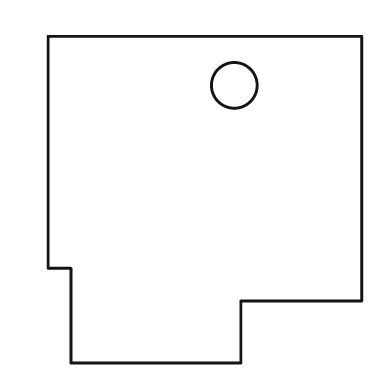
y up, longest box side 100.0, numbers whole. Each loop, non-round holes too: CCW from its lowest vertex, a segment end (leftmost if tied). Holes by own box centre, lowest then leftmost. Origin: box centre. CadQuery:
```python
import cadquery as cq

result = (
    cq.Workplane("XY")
    .moveTo(-41.0, -50.0)
    .lineTo(11.0, -50.0)
    .lineTo(11.0, -31.0)
    .lineTo(48.0, -31.0)
    .lineTo(48.0, 50.0)
    .lineTo(-48.0, 50.0)
    .lineTo(-48.0, -21.0)
    .lineTo(-41.0, -21.0)
    .close()
    .moveTo(9.0, 35.0)
    .circle(7.0)
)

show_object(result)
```